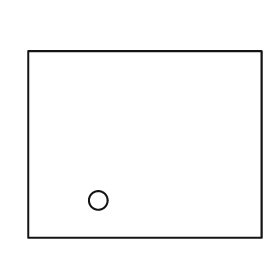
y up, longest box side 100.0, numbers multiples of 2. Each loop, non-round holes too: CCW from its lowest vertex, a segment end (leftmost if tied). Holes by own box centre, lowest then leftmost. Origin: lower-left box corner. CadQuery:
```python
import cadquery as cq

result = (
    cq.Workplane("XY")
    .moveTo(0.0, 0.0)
    .lineTo(100.0, 0.0)
    .lineTo(100.0, 80.0)
    .lineTo(0.0, 80.0)
    .close()
    .moveTo(30.0, 16.0)
    .circle(4.0)
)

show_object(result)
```